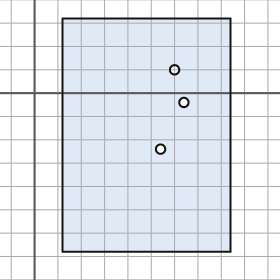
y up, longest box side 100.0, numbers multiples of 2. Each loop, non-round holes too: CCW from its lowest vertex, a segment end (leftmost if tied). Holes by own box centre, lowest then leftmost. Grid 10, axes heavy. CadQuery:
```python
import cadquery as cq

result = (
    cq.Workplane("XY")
    .moveTo(12.0, -68.0)
    .lineTo(84.0, -68.0)
    .lineTo(84.0, 32.0)
    .lineTo(12.0, 32.0)
    .close()
    .moveTo(54.0, -24.0)
    .circle(2.0)
    .moveTo(64.0, -4.0)
    .circle(2.0)
    .moveTo(60.0, 10.0)
    .circle(2.0)
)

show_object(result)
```